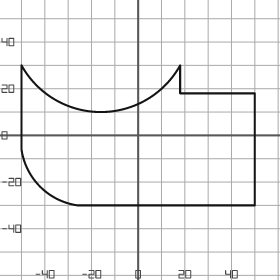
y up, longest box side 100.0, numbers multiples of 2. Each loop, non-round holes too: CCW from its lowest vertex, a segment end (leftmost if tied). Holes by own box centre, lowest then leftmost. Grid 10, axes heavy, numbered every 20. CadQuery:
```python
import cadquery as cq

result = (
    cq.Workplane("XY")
    .moveTo(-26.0, -30.0)
    .lineTo(50.0, -30.0)
    .lineTo(50.0, 18.0)
    .lineTo(18.0, 18.0)
    .lineTo(18.0, 30.0)
    .threePointArc((-16.0, 10.0), (-50.0, 30.0))
    .lineTo(-50.0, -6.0)
    .threePointArc((-42.0, -22.0), (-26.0, -30.0))
    .close()
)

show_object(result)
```